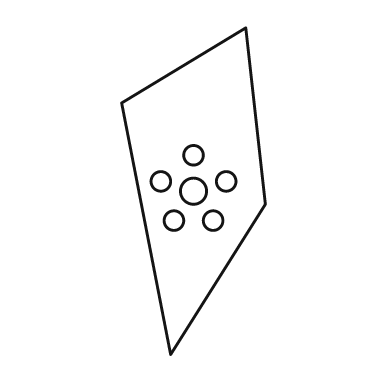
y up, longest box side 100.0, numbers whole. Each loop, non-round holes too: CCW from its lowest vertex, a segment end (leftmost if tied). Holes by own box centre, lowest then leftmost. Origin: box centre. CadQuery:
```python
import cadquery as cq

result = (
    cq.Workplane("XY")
    .moveTo(-7.0, -50.0)
    .lineTo(22.0, -4.0)
    .lineTo(16.0, 50.0)
    .lineTo(-22.0, 27.0)
    .close()
    .moveTo(-6.0, -9.0)
    .circle(3.0)
    .moveTo(6.0, -9.0)
    .circle(3.0)
    .moveTo(0.0, 0.0)
    .circle(4.0)
    .moveTo(-10.0, 3.0)
    .circle(3.0)
    .moveTo(10.0, 3.0)
    .circle(3.0)
    .moveTo(0.0, 11.0)
    .circle(3.0)
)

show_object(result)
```